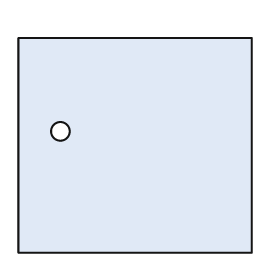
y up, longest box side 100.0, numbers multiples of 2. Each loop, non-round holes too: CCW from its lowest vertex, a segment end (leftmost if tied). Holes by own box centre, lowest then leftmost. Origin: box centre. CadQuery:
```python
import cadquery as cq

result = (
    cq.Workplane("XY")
    .moveTo(-50.0, -46.0)
    .lineTo(50.0, -46.0)
    .lineTo(50.0, 46.0)
    .lineTo(-50.0, 46.0)
    .close()
    .moveTo(-32.0, 6.0)
    .circle(4.0)
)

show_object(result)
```